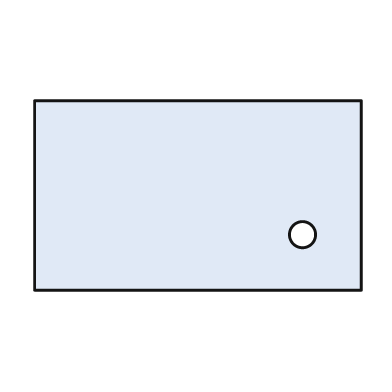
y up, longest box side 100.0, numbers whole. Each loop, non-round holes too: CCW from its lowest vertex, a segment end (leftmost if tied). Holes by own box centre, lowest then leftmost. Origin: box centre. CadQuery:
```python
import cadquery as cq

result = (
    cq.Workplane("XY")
    .moveTo(-50.0, -29.0)
    .lineTo(50.0, -29.0)
    .lineTo(50.0, 29.0)
    .lineTo(-50.0, 29.0)
    .close()
    .moveTo(32.0, -12.0)
    .circle(4.0)
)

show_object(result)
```